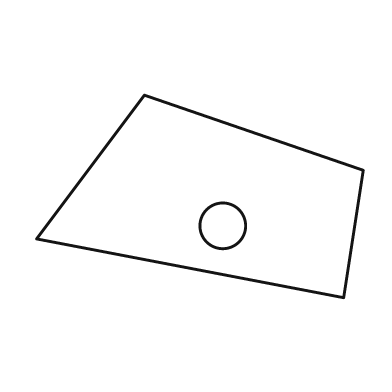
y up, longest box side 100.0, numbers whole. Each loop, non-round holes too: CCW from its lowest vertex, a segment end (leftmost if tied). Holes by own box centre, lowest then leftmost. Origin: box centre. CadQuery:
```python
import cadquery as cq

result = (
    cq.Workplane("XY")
    .moveTo(44.0, -31.0)
    .lineTo(50.0, 8.0)
    .lineTo(-17.0, 31.0)
    .lineTo(-50.0, -13.0)
    .close()
    .moveTo(7.0, -9.0)
    .circle(7.0)
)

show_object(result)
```